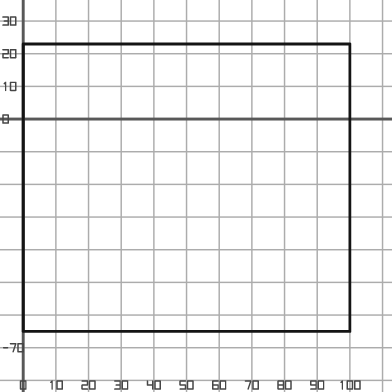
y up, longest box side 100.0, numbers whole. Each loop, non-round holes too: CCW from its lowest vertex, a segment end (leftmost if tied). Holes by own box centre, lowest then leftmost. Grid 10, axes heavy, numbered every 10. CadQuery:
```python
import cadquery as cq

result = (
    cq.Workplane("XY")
    .moveTo(0.0, -65.0)
    .lineTo(100.0, -65.0)
    .lineTo(100.0, 23.0)
    .lineTo(0.0, 23.0)
    .close()
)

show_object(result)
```